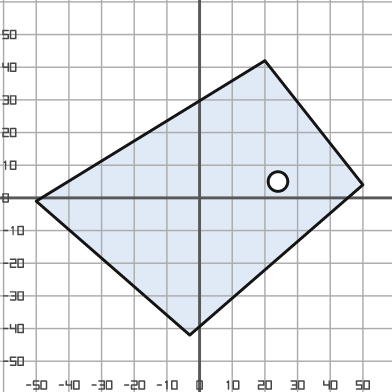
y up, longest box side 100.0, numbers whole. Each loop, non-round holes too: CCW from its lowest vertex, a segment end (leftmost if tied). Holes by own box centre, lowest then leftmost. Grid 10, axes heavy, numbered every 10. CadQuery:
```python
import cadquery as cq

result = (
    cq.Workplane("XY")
    .moveTo(-3.0, -42.0)
    .lineTo(50.0, 4.0)
    .lineTo(20.0, 42.0)
    .lineTo(-50.0, -1.0)
    .close()
    .moveTo(24.0, 5.0)
    .circle(3.0)
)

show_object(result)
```